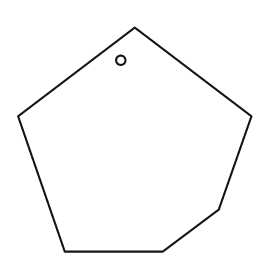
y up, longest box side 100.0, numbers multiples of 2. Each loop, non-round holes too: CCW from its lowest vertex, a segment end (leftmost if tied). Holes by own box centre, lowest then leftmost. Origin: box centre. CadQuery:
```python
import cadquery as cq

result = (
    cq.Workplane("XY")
    .moveTo(-30.0, -48.0)
    .lineTo(12.0, -48.0)
    .lineTo(36.0, -30.0)
    .lineTo(50.0, 10.0)
    .lineTo(0.0, 48.0)
    .lineTo(-50.0, 10.0)
    .close()
    .moveTo(-6.0, 34.0)
    .circle(2.0)
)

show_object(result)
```